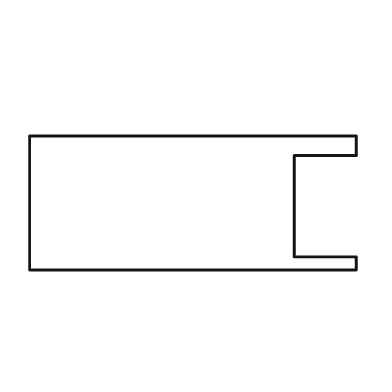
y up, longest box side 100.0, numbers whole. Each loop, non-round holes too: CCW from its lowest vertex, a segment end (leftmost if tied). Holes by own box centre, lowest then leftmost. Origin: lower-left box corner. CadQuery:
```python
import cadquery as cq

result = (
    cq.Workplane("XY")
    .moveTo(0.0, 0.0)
    .lineTo(100.0, 0.0)
    .lineTo(100.0, 4.0)
    .lineTo(81.0, 4.0)
    .lineTo(81.0, 35.0)
    .lineTo(100.0, 35.0)
    .lineTo(100.0, 41.0)
    .lineTo(0.0, 41.0)
    .close()
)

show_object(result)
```